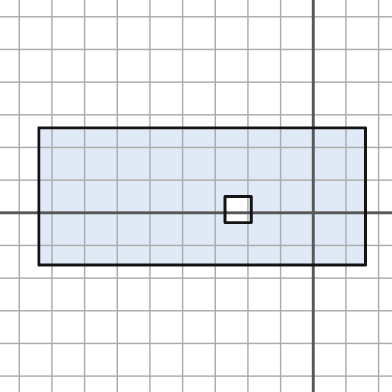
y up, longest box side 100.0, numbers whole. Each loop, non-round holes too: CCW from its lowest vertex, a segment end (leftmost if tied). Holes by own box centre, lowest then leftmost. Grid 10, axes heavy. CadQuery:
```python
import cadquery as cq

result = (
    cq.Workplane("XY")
    .moveTo(-84.0, -16.0)
    .lineTo(16.0, -16.0)
    .lineTo(16.0, 26.0)
    .lineTo(-84.0, 26.0)
    .close()
    .moveTo(-27.0, -3.0)
    .lineTo(-19.0, -3.0)
    .lineTo(-19.0, 5.0)
    .lineTo(-27.0, 5.0)
    .close()
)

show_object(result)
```